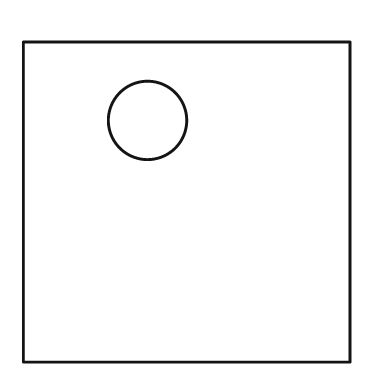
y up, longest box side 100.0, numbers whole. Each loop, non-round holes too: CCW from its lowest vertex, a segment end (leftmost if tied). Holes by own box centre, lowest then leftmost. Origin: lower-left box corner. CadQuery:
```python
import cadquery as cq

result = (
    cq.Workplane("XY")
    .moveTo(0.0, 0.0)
    .lineTo(100.0, 0.0)
    .lineTo(100.0, 98.0)
    .lineTo(0.0, 98.0)
    .close()
    .moveTo(38.0, 74.0)
    .circle(12.0)
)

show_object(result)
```